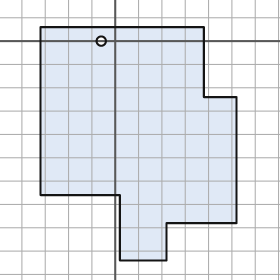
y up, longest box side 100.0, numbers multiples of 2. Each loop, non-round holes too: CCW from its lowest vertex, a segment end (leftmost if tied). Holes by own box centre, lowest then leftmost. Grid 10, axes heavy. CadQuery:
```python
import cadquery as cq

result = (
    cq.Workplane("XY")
    .moveTo(2.0, -94.0)
    .lineTo(22.0, -94.0)
    .lineTo(22.0, -78.0)
    .lineTo(52.0, -78.0)
    .lineTo(52.0, -24.0)
    .lineTo(38.0, -24.0)
    .lineTo(38.0, 6.0)
    .lineTo(-32.0, 6.0)
    .lineTo(-32.0, -66.0)
    .lineTo(2.0, -66.0)
    .close()
    .moveTo(-6.0, 0.0)
    .circle(2.0)
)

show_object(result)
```